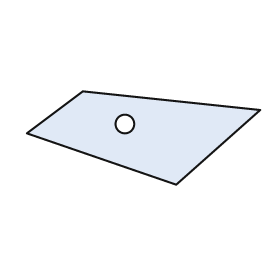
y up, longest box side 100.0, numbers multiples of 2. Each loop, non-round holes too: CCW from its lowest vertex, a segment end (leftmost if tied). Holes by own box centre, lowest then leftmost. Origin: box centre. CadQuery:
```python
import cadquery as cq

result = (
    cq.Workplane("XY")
    .moveTo(14.0, -20.0)
    .lineTo(50.0, 12.0)
    .lineTo(-26.0, 20.0)
    .lineTo(-50.0, 2.0)
    .close()
    .moveTo(-8.0, 6.0)
    .circle(4.0)
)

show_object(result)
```